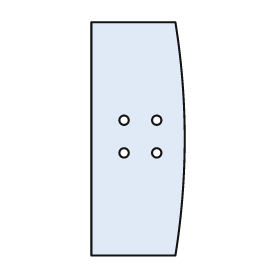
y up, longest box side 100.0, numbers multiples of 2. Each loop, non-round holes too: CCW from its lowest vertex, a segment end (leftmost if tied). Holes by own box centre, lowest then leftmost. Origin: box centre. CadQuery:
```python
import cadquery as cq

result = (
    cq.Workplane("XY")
    .moveTo(-20.0, -50.0)
    .lineTo(16.0, -50.0)
    .threePointArc((20.0, 0.0), (16.0, 50.0))
    .lineTo(-20.0, 50.0)
    .close()
    .moveTo(-6.0, -6.0)
    .circle(2.0)
    .moveTo(8.0, -6.0)
    .circle(2.0)
    .moveTo(-6.0, 8.0)
    .circle(2.0)
    .moveTo(8.0, 8.0)
    .circle(2.0)
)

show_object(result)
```